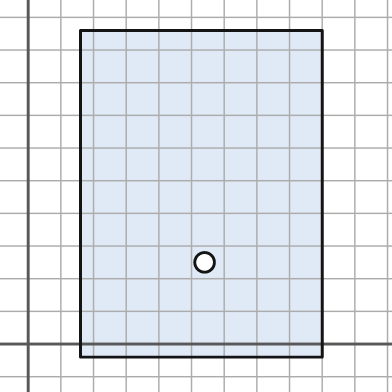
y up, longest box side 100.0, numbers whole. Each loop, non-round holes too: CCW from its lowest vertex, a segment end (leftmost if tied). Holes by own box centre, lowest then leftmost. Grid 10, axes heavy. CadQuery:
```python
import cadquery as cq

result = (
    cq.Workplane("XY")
    .moveTo(16.0, -4.0)
    .lineTo(90.0, -4.0)
    .lineTo(90.0, 96.0)
    .lineTo(16.0, 96.0)
    .close()
    .moveTo(54.0, 25.0)
    .circle(3.0)
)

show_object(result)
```